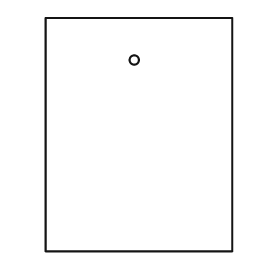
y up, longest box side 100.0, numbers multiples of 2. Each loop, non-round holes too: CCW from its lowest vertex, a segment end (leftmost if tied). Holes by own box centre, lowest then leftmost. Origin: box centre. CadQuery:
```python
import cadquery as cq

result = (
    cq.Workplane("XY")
    .moveTo(-40.0, -50.0)
    .lineTo(40.0, -50.0)
    .lineTo(40.0, 50.0)
    .lineTo(-40.0, 50.0)
    .close()
    .moveTo(-2.0, 32.0)
    .circle(2.0)
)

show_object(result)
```